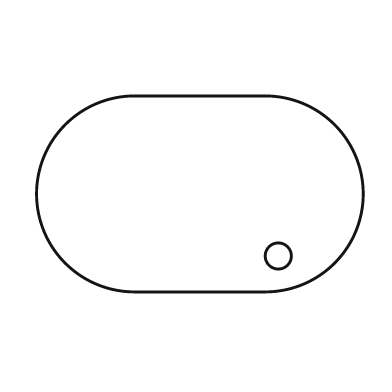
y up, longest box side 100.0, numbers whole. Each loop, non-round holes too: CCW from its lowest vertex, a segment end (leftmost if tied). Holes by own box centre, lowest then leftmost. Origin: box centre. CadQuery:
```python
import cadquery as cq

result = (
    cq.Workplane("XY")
    .moveTo(-20.0, -30.0)
    .lineTo(20.0, -30.0)
    .threePointArc((50.0, 0.0), (20.0, 30.0))
    .lineTo(-20.0, 30.0)
    .threePointArc((-50.0, 0.0), (-20.0, -30.0))
    .close()
    .moveTo(24.0, -19.0)
    .circle(4.0)
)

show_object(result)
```